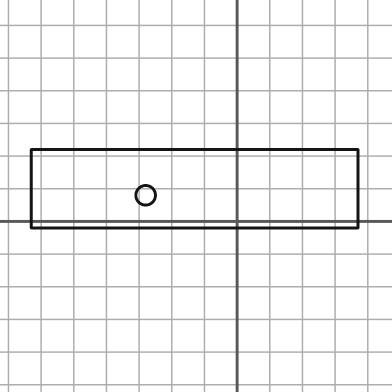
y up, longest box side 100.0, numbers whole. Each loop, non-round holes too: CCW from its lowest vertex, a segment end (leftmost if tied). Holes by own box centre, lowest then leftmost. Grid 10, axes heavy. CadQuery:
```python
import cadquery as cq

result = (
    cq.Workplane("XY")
    .moveTo(-63.0, -2.0)
    .lineTo(37.0, -2.0)
    .lineTo(37.0, 22.0)
    .lineTo(-63.0, 22.0)
    .close()
    .moveTo(-28.0, 8.0)
    .circle(3.0)
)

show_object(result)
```